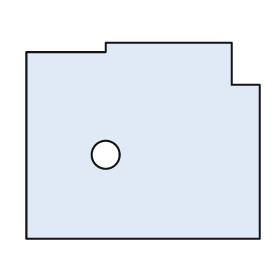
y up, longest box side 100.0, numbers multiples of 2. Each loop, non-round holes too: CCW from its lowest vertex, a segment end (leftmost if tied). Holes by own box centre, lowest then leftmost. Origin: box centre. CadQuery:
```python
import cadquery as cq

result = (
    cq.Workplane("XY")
    .moveTo(-50.0, -42.0)
    .lineTo(50.0, -42.0)
    .lineTo(50.0, 24.0)
    .lineTo(38.0, 24.0)
    .lineTo(38.0, 42.0)
    .lineTo(-16.0, 42.0)
    .lineTo(-16.0, 38.0)
    .lineTo(-50.0, 38.0)
    .close()
    .moveTo(-16.0, -6.0)
    .circle(6.0)
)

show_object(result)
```